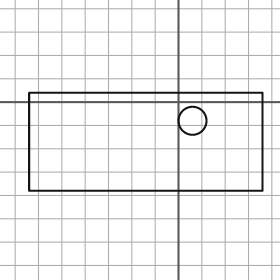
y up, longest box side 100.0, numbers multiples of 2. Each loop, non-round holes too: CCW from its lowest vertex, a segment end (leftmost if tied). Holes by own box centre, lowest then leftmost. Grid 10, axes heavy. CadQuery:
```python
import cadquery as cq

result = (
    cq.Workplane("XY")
    .moveTo(-64.0, -38.0)
    .lineTo(36.0, -38.0)
    .lineTo(36.0, 4.0)
    .lineTo(-64.0, 4.0)
    .close()
    .moveTo(6.0, -8.0)
    .circle(6.0)
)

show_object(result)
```